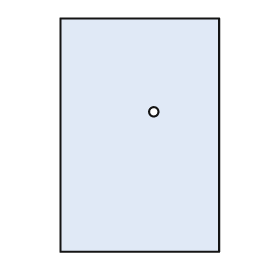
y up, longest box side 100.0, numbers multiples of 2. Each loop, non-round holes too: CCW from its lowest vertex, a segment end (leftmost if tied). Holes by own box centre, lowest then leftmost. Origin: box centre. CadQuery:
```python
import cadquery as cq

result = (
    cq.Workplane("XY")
    .moveTo(-34.0, -50.0)
    .lineTo(34.0, -50.0)
    .lineTo(34.0, 50.0)
    .lineTo(-34.0, 50.0)
    .close()
    .moveTo(6.0, 10.0)
    .circle(2.0)
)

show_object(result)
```